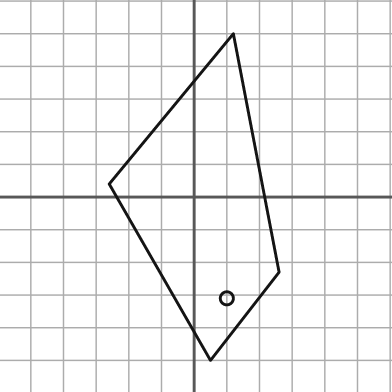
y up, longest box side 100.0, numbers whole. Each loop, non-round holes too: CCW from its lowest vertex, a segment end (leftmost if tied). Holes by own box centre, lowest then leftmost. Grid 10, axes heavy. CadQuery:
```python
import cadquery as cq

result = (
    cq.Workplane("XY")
    .moveTo(5.0, -50.0)
    .lineTo(26.0, -23.0)
    .lineTo(12.0, 50.0)
    .lineTo(-26.0, 4.0)
    .close()
    .moveTo(10.0, -31.0)
    .circle(2.0)
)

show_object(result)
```